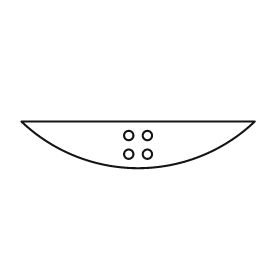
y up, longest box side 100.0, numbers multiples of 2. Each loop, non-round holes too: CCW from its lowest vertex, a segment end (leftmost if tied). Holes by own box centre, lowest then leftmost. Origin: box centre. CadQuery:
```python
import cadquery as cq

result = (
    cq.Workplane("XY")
    .moveTo(-50.0, 10.0)
    .threePointArc((0.0, -10.0), (50.0, 10.0))
    .close()
    .moveTo(-4.0, -4.0)
    .circle(2.0)
    .moveTo(4.0, -4.0)
    .circle(2.0)
    .moveTo(-4.0, 4.0)
    .circle(2.0)
    .moveTo(4.0, 4.0)
    .circle(2.0)
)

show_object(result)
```